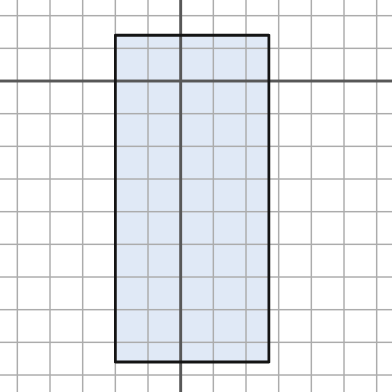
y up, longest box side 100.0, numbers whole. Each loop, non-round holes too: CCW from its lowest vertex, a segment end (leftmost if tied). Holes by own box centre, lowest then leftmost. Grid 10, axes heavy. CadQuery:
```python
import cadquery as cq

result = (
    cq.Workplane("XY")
    .moveTo(-20.0, -86.0)
    .lineTo(27.0, -86.0)
    .lineTo(27.0, 14.0)
    .lineTo(-20.0, 14.0)
    .close()
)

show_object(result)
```